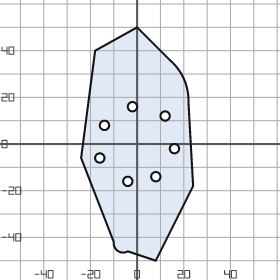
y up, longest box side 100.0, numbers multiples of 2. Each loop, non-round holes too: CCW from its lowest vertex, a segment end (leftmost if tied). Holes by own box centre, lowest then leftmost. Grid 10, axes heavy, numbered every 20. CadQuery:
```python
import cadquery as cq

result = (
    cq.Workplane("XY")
    .moveTo(8.0, -50.0)
    .lineTo(24.0, -18.0)
    .lineTo(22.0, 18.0)
    .threePointArc((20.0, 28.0), (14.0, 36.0))
    .lineTo(0.0, 50.0)
    .lineTo(-18.0, 40.0)
    .lineTo(-24.0, -6.0)
    .lineTo(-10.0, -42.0)
    .threePointArc((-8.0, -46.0), (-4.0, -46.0))
    .close()
    .moveTo(-4.0, -16.0)
    .circle(2.0)
    .moveTo(8.0, -14.0)
    .circle(2.0)
    .moveTo(-16.0, -6.0)
    .circle(2.0)
    .moveTo(16.0, -2.0)
    .circle(2.0)
    .moveTo(-14.0, 8.0)
    .circle(2.0)
    .moveTo(12.0, 12.0)
    .circle(2.0)
    .moveTo(-2.0, 16.0)
    .circle(2.0)
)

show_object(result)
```